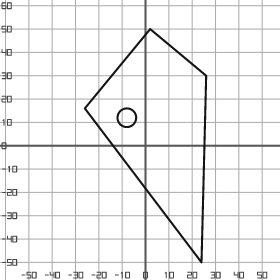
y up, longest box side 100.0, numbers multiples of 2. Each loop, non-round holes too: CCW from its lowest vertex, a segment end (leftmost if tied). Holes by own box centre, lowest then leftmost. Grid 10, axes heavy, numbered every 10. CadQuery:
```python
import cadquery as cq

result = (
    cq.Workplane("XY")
    .moveTo(24.0, -50.0)
    .lineTo(26.0, 30.0)
    .lineTo(2.0, 50.0)
    .lineTo(-26.0, 16.0)
    .close()
    .moveTo(-8.0, 12.0)
    .circle(4.0)
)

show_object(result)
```